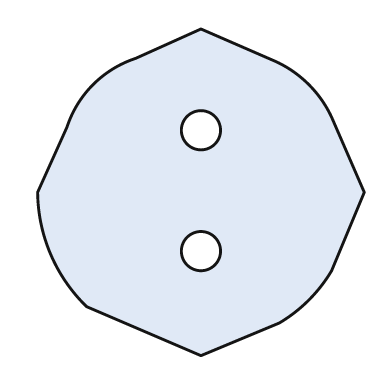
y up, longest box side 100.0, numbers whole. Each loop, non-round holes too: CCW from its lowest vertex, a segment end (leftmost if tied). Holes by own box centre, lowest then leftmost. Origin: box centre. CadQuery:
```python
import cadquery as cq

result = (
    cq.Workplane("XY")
    .moveTo(0.0, -50.0)
    .lineTo(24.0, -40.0)
    .threePointArc((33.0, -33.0), (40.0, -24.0))
    .lineTo(50.0, 0.0)
    .lineTo(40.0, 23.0)
    .threePointArc((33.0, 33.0), (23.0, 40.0))
    .lineTo(0.0, 50.0)
    .lineTo(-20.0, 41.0)
    .threePointArc((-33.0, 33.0), (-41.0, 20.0))
    .lineTo(-50.0, 0.0)
    .threePointArc((-46.0, -19.0), (-35.0, -35.0))
    .close()
    .moveTo(0.0, -18.0)
    .circle(6.0)
    .moveTo(0.0, 19.0)
    .circle(6.0)
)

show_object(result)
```